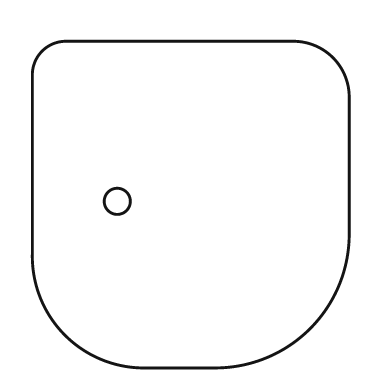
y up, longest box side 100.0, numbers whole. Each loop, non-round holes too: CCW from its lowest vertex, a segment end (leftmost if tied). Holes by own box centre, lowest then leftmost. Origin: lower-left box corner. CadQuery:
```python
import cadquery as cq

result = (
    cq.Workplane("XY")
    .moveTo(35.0, 0.0)
    .lineTo(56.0, 0.0)
    .threePointArc((85.0, 12.0), (97.0, 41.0))
    .lineTo(97.0, 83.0)
    .threePointArc((92.0, 95.0), (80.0, 100.0))
    .lineTo(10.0, 100.0)
    .threePointArc((3.0, 97.0), (0.0, 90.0))
    .lineTo(0.0, 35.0)
    .threePointArc((10.0, 10.0), (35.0, 0.0))
    .close()
    .moveTo(26.0, 51.0)
    .circle(4.0)
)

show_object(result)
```